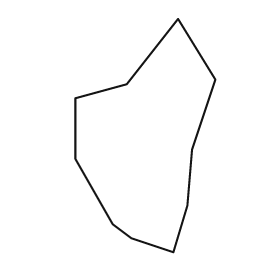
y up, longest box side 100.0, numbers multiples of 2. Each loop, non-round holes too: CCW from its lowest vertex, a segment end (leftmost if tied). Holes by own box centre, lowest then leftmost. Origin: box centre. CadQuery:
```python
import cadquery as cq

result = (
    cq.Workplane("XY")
    .moveTo(12.0, -50.0)
    .lineTo(18.0, -30.0)
    .lineTo(20.0, -6.0)
    .lineTo(30.0, 24.0)
    .lineTo(14.0, 50.0)
    .lineTo(-8.0, 22.0)
    .lineTo(-30.0, 16.0)
    .lineTo(-30.0, -10.0)
    .lineTo(-14.0, -38.0)
    .lineTo(-6.0, -44.0)
    .close()
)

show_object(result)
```